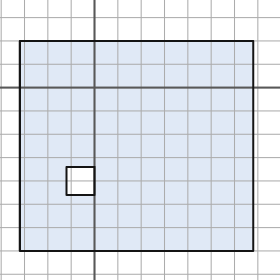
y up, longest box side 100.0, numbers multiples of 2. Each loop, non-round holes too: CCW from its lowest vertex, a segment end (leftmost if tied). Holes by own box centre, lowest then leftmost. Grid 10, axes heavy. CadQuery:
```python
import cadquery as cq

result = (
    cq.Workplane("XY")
    .moveTo(-32.0, -70.0)
    .lineTo(68.0, -70.0)
    .lineTo(68.0, 20.0)
    .lineTo(-32.0, 20.0)
    .close()
    .moveTo(-12.0, -46.0)
    .lineTo(0.0, -46.0)
    .lineTo(0.0, -34.0)
    .lineTo(-12.0, -34.0)
    .close()
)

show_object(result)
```